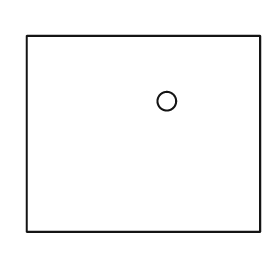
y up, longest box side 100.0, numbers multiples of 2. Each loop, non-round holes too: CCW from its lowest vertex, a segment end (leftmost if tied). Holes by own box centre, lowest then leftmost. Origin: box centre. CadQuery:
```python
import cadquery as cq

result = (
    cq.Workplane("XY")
    .moveTo(-50.0, -42.0)
    .lineTo(50.0, -42.0)
    .lineTo(50.0, 42.0)
    .lineTo(-50.0, 42.0)
    .close()
    .moveTo(10.0, 14.0)
    .circle(4.0)
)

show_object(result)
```